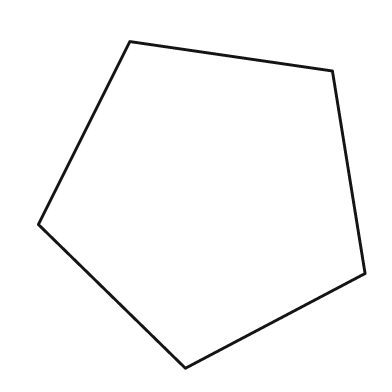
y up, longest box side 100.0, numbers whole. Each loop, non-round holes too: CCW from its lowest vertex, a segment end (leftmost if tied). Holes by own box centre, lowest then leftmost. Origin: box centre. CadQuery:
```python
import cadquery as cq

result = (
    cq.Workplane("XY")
    .moveTo(-5.0, -50.0)
    .lineTo(50.0, -21.0)
    .lineTo(40.0, 41.0)
    .lineTo(-22.0, 50.0)
    .lineTo(-50.0, -6.0)
    .close()
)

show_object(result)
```